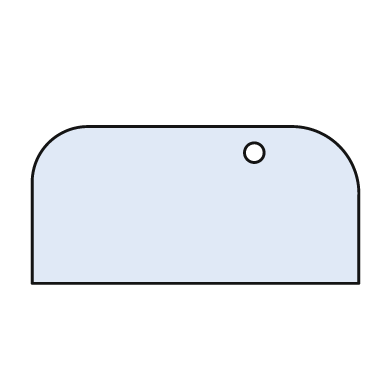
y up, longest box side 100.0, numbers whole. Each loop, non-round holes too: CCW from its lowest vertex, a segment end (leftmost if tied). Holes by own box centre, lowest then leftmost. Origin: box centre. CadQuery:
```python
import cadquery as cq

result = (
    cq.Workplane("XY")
    .moveTo(-50.0, -24.0)
    .lineTo(50.0, -24.0)
    .lineTo(50.0, 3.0)
    .threePointArc((44.0, 18.0), (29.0, 24.0))
    .lineTo(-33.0, 24.0)
    .threePointArc((-45.0, 19.0), (-50.0, 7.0))
    .close()
    .moveTo(18.0, 16.0)
    .circle(3.0)
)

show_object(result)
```